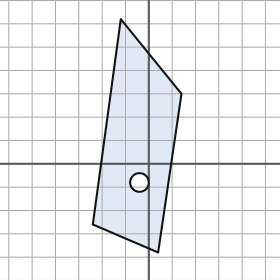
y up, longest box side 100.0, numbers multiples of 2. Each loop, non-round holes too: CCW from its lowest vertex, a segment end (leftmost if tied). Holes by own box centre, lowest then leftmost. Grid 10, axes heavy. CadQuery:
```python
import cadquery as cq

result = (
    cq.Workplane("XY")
    .moveTo(4.0, -38.0)
    .lineTo(14.0, 30.0)
    .lineTo(-12.0, 62.0)
    .lineTo(-24.0, -26.0)
    .close()
    .moveTo(-4.0, -8.0)
    .circle(4.0)
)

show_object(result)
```